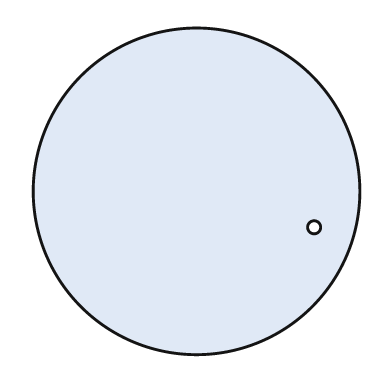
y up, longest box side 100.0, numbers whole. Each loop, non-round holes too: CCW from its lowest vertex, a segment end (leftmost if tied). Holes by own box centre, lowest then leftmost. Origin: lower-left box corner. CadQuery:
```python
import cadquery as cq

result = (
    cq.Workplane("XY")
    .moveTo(50.0, 50.0)
    .circle(50.0)
    .moveTo(86.0, 39.0)
    .circle(2.0)
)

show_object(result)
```